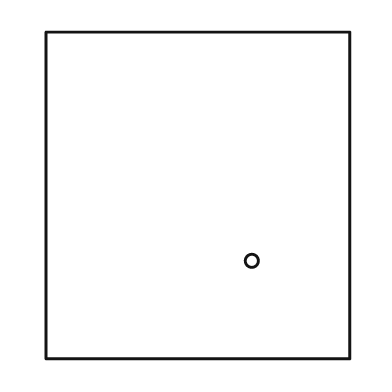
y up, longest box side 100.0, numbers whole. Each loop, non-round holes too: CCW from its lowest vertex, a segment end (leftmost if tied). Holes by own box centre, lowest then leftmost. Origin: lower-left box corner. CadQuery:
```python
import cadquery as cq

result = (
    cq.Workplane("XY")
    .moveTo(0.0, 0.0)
    .lineTo(93.0, 0.0)
    .lineTo(93.0, 100.0)
    .lineTo(0.0, 100.0)
    .close()
    .moveTo(63.0, 30.0)
    .circle(2.0)
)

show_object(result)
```